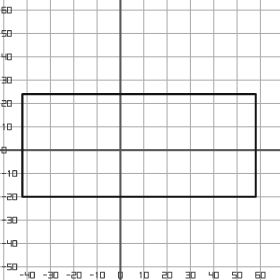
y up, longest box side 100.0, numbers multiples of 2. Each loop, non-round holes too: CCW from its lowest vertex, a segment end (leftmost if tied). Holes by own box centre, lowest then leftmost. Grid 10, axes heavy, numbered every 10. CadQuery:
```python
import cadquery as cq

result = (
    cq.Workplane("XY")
    .moveTo(-42.0, -20.0)
    .lineTo(58.0, -20.0)
    .lineTo(58.0, 24.0)
    .lineTo(-42.0, 24.0)
    .close()
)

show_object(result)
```